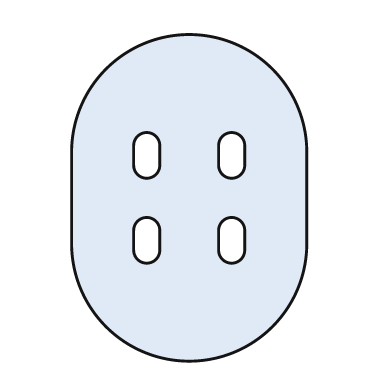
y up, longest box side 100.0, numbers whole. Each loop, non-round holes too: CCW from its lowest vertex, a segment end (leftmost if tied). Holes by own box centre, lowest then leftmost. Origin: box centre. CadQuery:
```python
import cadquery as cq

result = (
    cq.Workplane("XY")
    .moveTo(-36.0, -14.0)
    .threePointArc((0.0, -50.0), (36.0, -14.0))
    .lineTo(36.0, 14.0)
    .threePointArc((0.0, 50.0), (-36.0, 14.0))
    .close()
    .moveTo(-17.0, -16.0)
    .threePointArc((-13.0, -20.0), (-9.0, -16.0))
    .lineTo(-9.0, -10.0)
    .threePointArc((-13.0, -6.0), (-17.0, -10.0))
    .close()
    .moveTo(9.0, -16.0)
    .threePointArc((13.0, -20.0), (17.0, -16.0))
    .lineTo(17.0, -10.0)
    .threePointArc((13.0, -6.0), (9.0, -10.0))
    .close()
    .moveTo(-17.0, 10.0)
    .threePointArc((-13.0, 6.0), (-9.0, 10.0))
    .lineTo(-9.0, 16.0)
    .threePointArc((-13.0, 20.0), (-17.0, 16.0))
    .close()
    .moveTo(9.0, 10.0)
    .threePointArc((13.0, 6.0), (17.0, 10.0))
    .lineTo(17.0, 16.0)
    .threePointArc((13.0, 20.0), (9.0, 16.0))
    .close()
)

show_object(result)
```